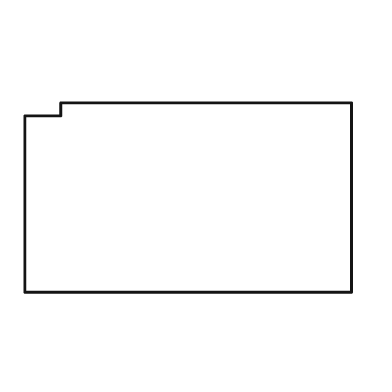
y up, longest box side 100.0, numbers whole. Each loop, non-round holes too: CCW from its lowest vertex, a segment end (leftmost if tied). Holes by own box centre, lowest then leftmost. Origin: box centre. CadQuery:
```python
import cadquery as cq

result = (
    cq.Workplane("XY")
    .moveTo(-50.0, -29.0)
    .lineTo(50.0, -29.0)
    .lineTo(50.0, 29.0)
    .lineTo(-39.0, 29.0)
    .lineTo(-39.0, 25.0)
    .lineTo(-50.0, 25.0)
    .close()
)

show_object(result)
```